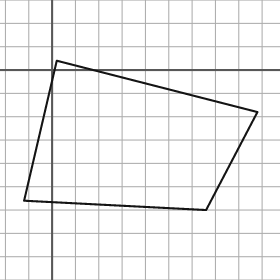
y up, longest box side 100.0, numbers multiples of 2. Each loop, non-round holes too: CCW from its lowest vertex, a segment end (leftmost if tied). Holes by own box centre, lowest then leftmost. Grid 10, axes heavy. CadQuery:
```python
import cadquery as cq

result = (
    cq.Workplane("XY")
    .moveTo(66.0, -60.0)
    .lineTo(88.0, -18.0)
    .lineTo(2.0, 4.0)
    .lineTo(-12.0, -56.0)
    .close()
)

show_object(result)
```